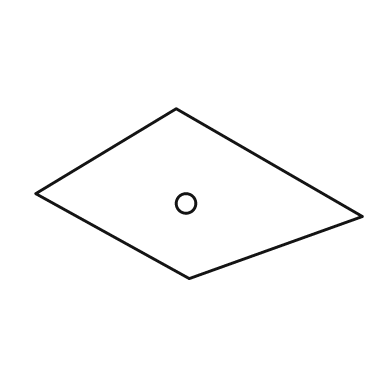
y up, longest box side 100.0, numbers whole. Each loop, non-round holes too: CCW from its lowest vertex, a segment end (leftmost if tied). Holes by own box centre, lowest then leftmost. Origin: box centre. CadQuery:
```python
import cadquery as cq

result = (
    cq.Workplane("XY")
    .moveTo(-3.0, -26.0)
    .lineTo(50.0, -7.0)
    .lineTo(-7.0, 26.0)
    .lineTo(-50.0, 0.0)
    .close()
    .moveTo(-4.0, -3.0)
    .circle(3.0)
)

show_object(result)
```